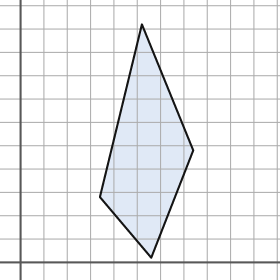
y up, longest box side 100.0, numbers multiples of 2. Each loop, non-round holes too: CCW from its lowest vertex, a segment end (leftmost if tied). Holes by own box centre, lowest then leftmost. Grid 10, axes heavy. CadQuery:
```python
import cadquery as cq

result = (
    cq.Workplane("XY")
    .moveTo(56.0, 2.0)
    .lineTo(74.0, 48.0)
    .lineTo(52.0, 102.0)
    .lineTo(34.0, 28.0)
    .close()
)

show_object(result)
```